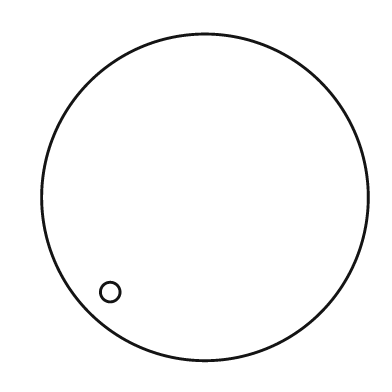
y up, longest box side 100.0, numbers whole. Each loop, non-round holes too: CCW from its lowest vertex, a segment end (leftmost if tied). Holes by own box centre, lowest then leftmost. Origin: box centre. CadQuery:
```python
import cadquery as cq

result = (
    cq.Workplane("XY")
    .moveTo(0.0, 0.0)
    .circle(50.0)
    .moveTo(-29.0, -29.0)
    .circle(3.0)
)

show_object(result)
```